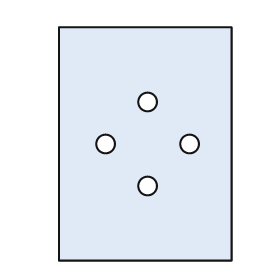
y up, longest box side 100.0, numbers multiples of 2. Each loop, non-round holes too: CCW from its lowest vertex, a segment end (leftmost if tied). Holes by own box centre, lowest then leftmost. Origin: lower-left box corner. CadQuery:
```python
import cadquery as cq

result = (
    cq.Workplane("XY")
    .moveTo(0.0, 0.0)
    .lineTo(74.0, 0.0)
    .lineTo(74.0, 100.0)
    .lineTo(0.0, 100.0)
    .close()
    .moveTo(38.0, 32.0)
    .circle(4.0)
    .moveTo(20.0, 50.0)
    .circle(4.0)
    .moveTo(56.0, 50.0)
    .circle(4.0)
    .moveTo(38.0, 68.0)
    .circle(4.0)
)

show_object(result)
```